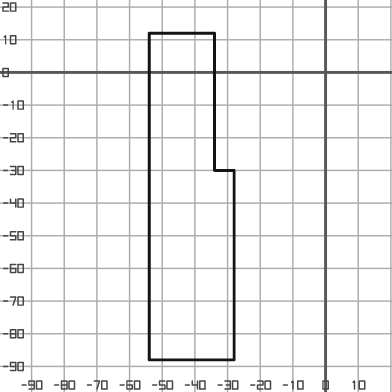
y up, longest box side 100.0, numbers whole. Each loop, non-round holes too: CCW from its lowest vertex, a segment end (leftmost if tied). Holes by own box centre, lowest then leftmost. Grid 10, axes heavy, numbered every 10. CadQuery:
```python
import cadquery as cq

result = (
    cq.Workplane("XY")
    .moveTo(-54.0, -88.0)
    .lineTo(-28.0, -88.0)
    .lineTo(-28.0, -30.0)
    .lineTo(-34.0, -30.0)
    .lineTo(-34.0, 12.0)
    .lineTo(-54.0, 12.0)
    .close()
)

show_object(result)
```